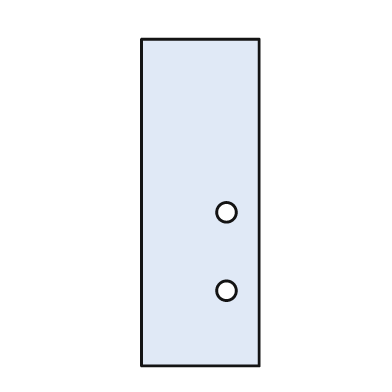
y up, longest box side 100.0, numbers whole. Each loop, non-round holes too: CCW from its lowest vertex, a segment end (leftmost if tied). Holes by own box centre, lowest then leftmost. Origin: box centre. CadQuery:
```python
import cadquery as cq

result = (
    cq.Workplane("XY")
    .moveTo(-18.0, -50.0)
    .lineTo(18.0, -50.0)
    .lineTo(18.0, 50.0)
    .lineTo(-18.0, 50.0)
    .close()
    .moveTo(8.0, -27.0)
    .circle(3.0)
    .moveTo(8.0, -3.0)
    .circle(3.0)
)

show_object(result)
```